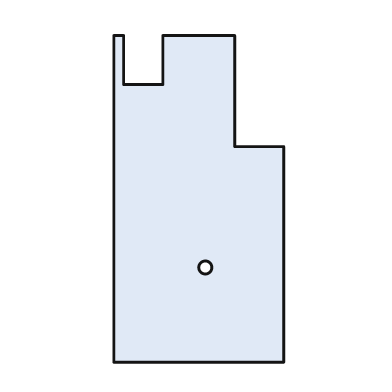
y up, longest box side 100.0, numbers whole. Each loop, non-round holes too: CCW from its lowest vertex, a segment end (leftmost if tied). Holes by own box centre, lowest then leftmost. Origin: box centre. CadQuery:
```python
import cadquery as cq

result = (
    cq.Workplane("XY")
    .moveTo(-26.0, -50.0)
    .lineTo(26.0, -50.0)
    .lineTo(26.0, 16.0)
    .lineTo(11.0, 16.0)
    .lineTo(11.0, 50.0)
    .lineTo(-11.0, 50.0)
    .lineTo(-11.0, 35.0)
    .lineTo(-23.0, 35.0)
    .lineTo(-23.0, 50.0)
    .lineTo(-26.0, 50.0)
    .close()
    .moveTo(2.0, -21.0)
    .circle(2.0)
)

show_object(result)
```